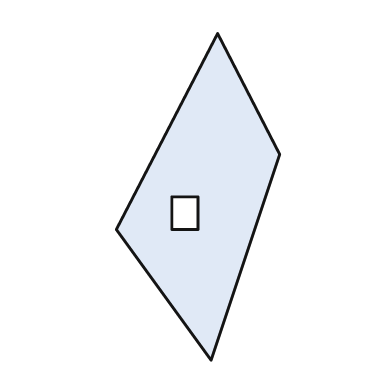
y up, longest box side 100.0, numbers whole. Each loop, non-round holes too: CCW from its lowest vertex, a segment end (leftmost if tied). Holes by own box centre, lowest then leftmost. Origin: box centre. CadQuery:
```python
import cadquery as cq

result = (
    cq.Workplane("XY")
    .moveTo(4.0, -50.0)
    .lineTo(25.0, 13.0)
    .lineTo(6.0, 50.0)
    .lineTo(-25.0, -10.0)
    .close()
    .moveTo(-8.0, -10.0)
    .lineTo(0.0, -10.0)
    .lineTo(0.0, 0.0)
    .lineTo(-8.0, 0.0)
    .close()
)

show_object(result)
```